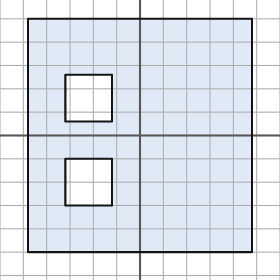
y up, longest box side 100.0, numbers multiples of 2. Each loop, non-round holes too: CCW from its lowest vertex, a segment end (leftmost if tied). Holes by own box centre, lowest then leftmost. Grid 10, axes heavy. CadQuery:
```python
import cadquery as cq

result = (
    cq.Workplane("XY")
    .moveTo(-48.0, -50.0)
    .lineTo(48.0, -50.0)
    .lineTo(48.0, 50.0)
    .lineTo(-48.0, 50.0)
    .close()
    .moveTo(-32.0, -30.0)
    .lineTo(-12.0, -30.0)
    .lineTo(-12.0, -10.0)
    .lineTo(-32.0, -10.0)
    .close()
    .moveTo(-32.0, 6.0)
    .lineTo(-12.0, 6.0)
    .lineTo(-12.0, 26.0)
    .lineTo(-32.0, 26.0)
    .close()
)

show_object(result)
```